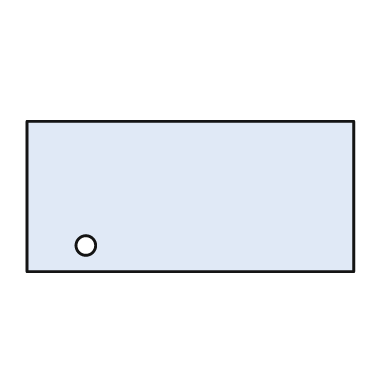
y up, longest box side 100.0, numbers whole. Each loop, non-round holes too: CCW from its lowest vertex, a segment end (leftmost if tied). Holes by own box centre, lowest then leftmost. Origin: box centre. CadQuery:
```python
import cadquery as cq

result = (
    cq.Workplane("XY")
    .moveTo(-50.0, -23.0)
    .lineTo(50.0, -23.0)
    .lineTo(50.0, 23.0)
    .lineTo(-50.0, 23.0)
    .close()
    .moveTo(-32.0, -15.0)
    .circle(3.0)
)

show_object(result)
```